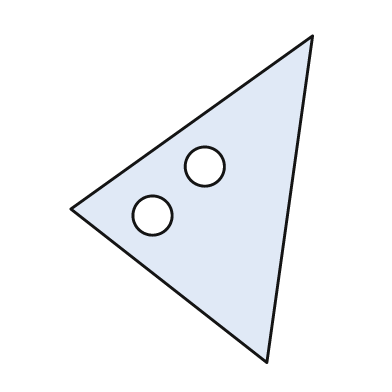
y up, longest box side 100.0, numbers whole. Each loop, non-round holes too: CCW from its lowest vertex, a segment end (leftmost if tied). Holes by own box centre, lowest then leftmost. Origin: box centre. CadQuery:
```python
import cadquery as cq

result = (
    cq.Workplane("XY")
    .moveTo(23.0, -50.0)
    .lineTo(37.0, 50.0)
    .lineTo(-37.0, -3.0)
    .close()
    .moveTo(-12.0, -5.0)
    .circle(6.0)
    .moveTo(4.0, 10.0)
    .circle(6.0)
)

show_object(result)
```